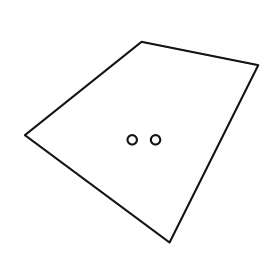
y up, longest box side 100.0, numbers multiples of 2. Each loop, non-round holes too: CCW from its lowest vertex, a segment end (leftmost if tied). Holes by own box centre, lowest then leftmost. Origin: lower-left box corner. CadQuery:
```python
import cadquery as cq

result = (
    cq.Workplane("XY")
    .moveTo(62.0, 0.0)
    .lineTo(100.0, 76.0)
    .lineTo(50.0, 86.0)
    .lineTo(0.0, 46.0)
    .close()
    .moveTo(46.0, 44.0)
    .circle(2.0)
    .moveTo(56.0, 44.0)
    .circle(2.0)
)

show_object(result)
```